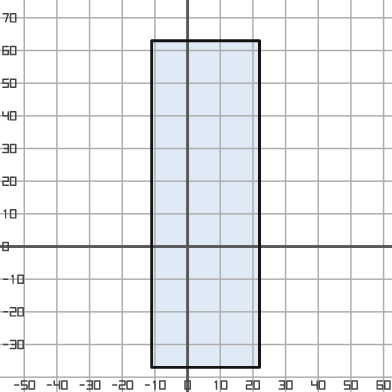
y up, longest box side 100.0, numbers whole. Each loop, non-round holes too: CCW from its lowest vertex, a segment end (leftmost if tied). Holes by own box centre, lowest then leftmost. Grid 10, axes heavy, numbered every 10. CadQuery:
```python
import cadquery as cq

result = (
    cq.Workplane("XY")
    .moveTo(-11.0, -37.0)
    .lineTo(22.0, -37.0)
    .lineTo(22.0, 63.0)
    .lineTo(-11.0, 63.0)
    .close()
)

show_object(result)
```